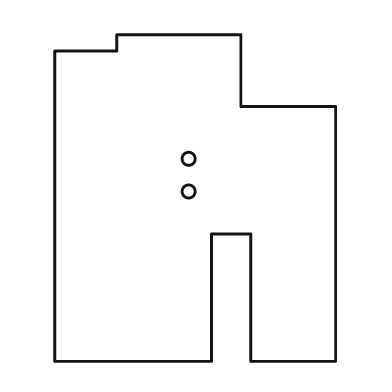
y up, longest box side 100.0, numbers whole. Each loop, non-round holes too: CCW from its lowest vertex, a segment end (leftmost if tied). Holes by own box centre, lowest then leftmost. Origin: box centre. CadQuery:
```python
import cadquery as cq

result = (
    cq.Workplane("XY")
    .moveTo(-43.0, -50.0)
    .lineTo(5.0, -50.0)
    .lineTo(5.0, -11.0)
    .lineTo(17.0, -11.0)
    .lineTo(17.0, -50.0)
    .lineTo(43.0, -50.0)
    .lineTo(43.0, 28.0)
    .lineTo(14.0, 28.0)
    .lineTo(14.0, 50.0)
    .lineTo(-24.0, 50.0)
    .lineTo(-24.0, 45.0)
    .lineTo(-43.0, 45.0)
    .close()
    .moveTo(-2.0, 2.0)
    .circle(2.0)
    .moveTo(-2.0, 12.0)
    .circle(2.0)
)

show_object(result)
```